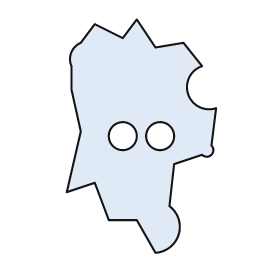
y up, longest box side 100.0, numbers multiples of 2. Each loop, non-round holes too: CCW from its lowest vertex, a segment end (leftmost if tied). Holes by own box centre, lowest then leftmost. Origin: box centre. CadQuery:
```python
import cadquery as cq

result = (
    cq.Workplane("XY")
    .moveTo(6.0, -50.0)
    .threePointArc((16.0, -42.0), (12.0, -30.0))
    .lineTo(14.0, -12.0)
    .lineTo(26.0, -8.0)
    .threePointArc((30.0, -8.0), (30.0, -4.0))
    .lineTo(32.0, 12.0)
    .threePointArc((20.0, 18.0), (26.0, 30.0))
    .lineTo(18.0, 40.0)
    .lineTo(6.0, 38.0)
    .lineTo(-2.0, 50.0)
    .lineTo(-8.0, 42.0)
    .lineTo(-20.0, 48.0)
    .lineTo(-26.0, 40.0)
    .threePointArc((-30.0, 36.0), (-30.0, 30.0))
    .lineTo(-30.0, 20.0)
    .lineTo(-26.0, 2.0)
    .lineTo(-32.0, -24.0)
    .lineTo(-20.0, -20.0)
    .lineTo(-14.0, -36.0)
    .lineTo(-2.0, -36.0)
    .close()
    .moveTo(-8.0, 0.0)
    .circle(6.0)
    .moveTo(8.0, 0.0)
    .circle(6.0)
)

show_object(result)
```